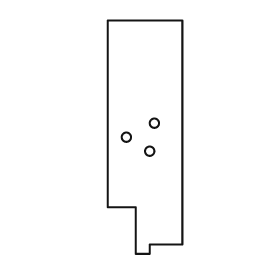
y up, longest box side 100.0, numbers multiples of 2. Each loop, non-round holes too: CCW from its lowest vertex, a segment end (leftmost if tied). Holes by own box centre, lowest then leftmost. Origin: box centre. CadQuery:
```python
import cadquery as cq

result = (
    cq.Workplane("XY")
    .moveTo(-4.0, -50.0)
    .lineTo(2.0, -50.0)
    .lineTo(2.0, -46.0)
    .lineTo(16.0, -46.0)
    .lineTo(16.0, 50.0)
    .lineTo(-16.0, 50.0)
    .lineTo(-16.0, -30.0)
    .lineTo(-4.0, -30.0)
    .close()
    .moveTo(2.0, -6.0)
    .circle(2.0)
    .moveTo(-8.0, 0.0)
    .circle(2.0)
    .moveTo(4.0, 6.0)
    .circle(2.0)
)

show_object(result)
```